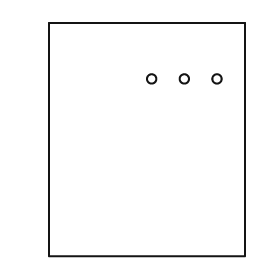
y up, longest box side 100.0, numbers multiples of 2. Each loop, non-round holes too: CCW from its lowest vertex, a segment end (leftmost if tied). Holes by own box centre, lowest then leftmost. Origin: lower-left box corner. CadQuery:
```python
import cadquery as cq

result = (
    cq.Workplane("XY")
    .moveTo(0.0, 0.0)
    .lineTo(84.0, 0.0)
    .lineTo(84.0, 100.0)
    .lineTo(0.0, 100.0)
    .close()
    .moveTo(44.0, 76.0)
    .circle(2.0)
    .moveTo(58.0, 76.0)
    .circle(2.0)
    .moveTo(72.0, 76.0)
    .circle(2.0)
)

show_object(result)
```